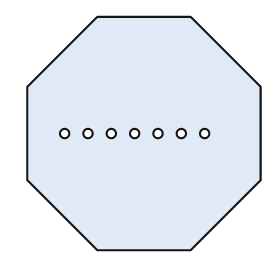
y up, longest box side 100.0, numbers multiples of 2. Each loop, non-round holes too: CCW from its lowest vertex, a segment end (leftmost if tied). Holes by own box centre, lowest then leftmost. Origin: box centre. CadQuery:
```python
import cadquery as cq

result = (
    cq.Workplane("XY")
    .moveTo(-20.0, -50.0)
    .lineTo(20.0, -50.0)
    .lineTo(50.0, -20.0)
    .lineTo(50.0, 20.0)
    .lineTo(20.0, 50.0)
    .lineTo(-20.0, 50.0)
    .lineTo(-50.0, 20.0)
    .lineTo(-50.0, -20.0)
    .close()
    .moveTo(-34.0, 0.0)
    .circle(2.0)
    .moveTo(-24.0, 0.0)
    .circle(2.0)
    .moveTo(-14.0, 0.0)
    .circle(2.0)
    .moveTo(-4.0, 0.0)
    .circle(2.0)
    .moveTo(6.0, 0.0)
    .circle(2.0)
    .moveTo(16.0, 0.0)
    .circle(2.0)
    .moveTo(26.0, 0.0)
    .circle(2.0)
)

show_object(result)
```